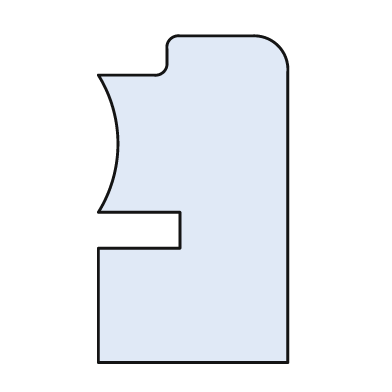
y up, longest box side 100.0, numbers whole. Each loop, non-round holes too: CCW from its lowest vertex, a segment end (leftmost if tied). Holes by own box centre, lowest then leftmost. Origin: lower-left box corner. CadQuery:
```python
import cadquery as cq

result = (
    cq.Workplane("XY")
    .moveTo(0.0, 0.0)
    .lineTo(58.0, 0.0)
    .lineTo(58.0, 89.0)
    .threePointArc((55.0, 97.0), (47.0, 100.0))
    .lineTo(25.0, 100.0)
    .threePointArc((22.0, 99.0), (21.0, 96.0))
    .lineTo(21.0, 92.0)
    .threePointArc((20.0, 89.0), (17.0, 88.0))
    .lineTo(0.0, 88.0)
    .threePointArc((6.0, 67.0), (0.0, 46.0))
    .lineTo(25.0, 46.0)
    .lineTo(25.0, 35.0)
    .lineTo(0.0, 35.0)
    .close()
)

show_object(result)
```